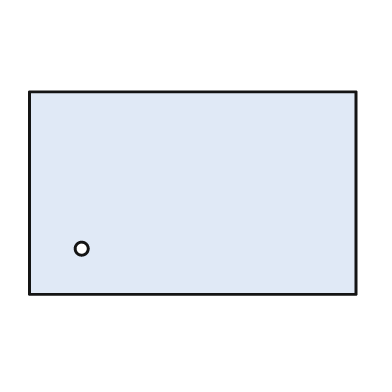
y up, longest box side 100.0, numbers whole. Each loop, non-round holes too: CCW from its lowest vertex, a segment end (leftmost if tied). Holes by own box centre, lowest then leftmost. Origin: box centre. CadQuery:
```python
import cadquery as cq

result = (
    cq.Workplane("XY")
    .moveTo(-50.0, -31.0)
    .lineTo(50.0, -31.0)
    .lineTo(50.0, 31.0)
    .lineTo(-50.0, 31.0)
    .close()
    .moveTo(-34.0, -17.0)
    .circle(2.0)
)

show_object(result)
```